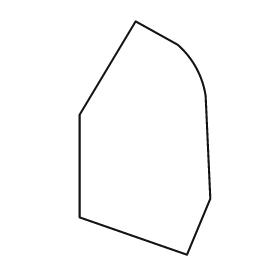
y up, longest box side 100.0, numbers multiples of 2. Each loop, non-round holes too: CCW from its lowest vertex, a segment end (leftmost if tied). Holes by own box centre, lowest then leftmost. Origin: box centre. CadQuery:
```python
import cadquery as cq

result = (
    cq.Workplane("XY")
    .moveTo(18.0, -50.0)
    .lineTo(28.0, -26.0)
    .lineTo(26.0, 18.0)
    .threePointArc((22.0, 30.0), (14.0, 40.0))
    .lineTo(-4.0, 50.0)
    .lineTo(-28.0, 10.0)
    .lineTo(-28.0, -34.0)
    .close()
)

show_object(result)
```